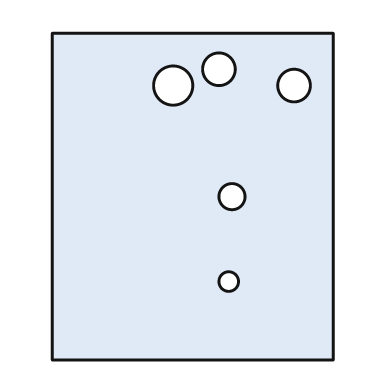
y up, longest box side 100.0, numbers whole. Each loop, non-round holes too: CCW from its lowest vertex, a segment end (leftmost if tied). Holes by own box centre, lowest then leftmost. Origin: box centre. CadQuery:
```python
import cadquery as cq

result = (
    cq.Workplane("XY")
    .moveTo(-43.0, -50.0)
    .lineTo(43.0, -50.0)
    .lineTo(43.0, 50.0)
    .lineTo(-43.0, 50.0)
    .close()
    .moveTo(11.0, -26.0)
    .circle(3.0)
    .moveTo(12.0, 0.0)
    .circle(4.0)
    .moveTo(-6.0, 34.0)
    .circle(6.0)
    .moveTo(31.0, 34.0)
    .circle(5.0)
    .moveTo(8.0, 39.0)
    .circle(5.0)
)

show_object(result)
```